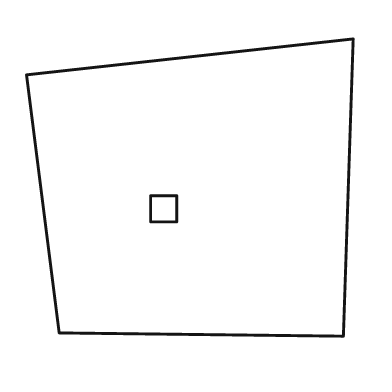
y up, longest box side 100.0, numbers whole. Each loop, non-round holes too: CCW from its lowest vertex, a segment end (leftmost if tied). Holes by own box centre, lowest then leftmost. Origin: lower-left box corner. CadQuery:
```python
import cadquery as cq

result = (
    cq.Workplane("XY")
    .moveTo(97.0, 0.0)
    .lineTo(100.0, 91.0)
    .lineTo(0.0, 80.0)
    .lineTo(10.0, 1.0)
    .close()
    .moveTo(38.0, 35.0)
    .lineTo(46.0, 35.0)
    .lineTo(46.0, 43.0)
    .lineTo(38.0, 43.0)
    .close()
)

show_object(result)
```